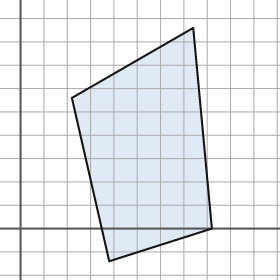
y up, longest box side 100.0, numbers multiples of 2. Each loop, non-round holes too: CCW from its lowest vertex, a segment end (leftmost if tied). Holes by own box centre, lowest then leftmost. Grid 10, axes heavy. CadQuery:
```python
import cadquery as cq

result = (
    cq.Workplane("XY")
    .moveTo(38.0, -14.0)
    .lineTo(82.0, 0.0)
    .lineTo(74.0, 86.0)
    .lineTo(22.0, 56.0)
    .close()
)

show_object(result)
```